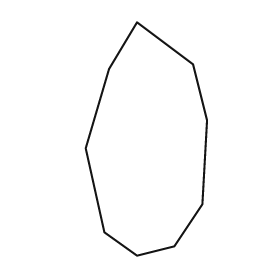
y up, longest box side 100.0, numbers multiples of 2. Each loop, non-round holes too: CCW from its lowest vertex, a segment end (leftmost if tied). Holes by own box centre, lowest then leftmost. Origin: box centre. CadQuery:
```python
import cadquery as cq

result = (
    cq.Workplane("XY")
    .moveTo(-4.0, -50.0)
    .lineTo(12.0, -46.0)
    .lineTo(24.0, -28.0)
    .lineTo(26.0, 8.0)
    .lineTo(20.0, 32.0)
    .lineTo(-4.0, 50.0)
    .lineTo(-16.0, 30.0)
    .lineTo(-26.0, -4.0)
    .lineTo(-18.0, -40.0)
    .close()
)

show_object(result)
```